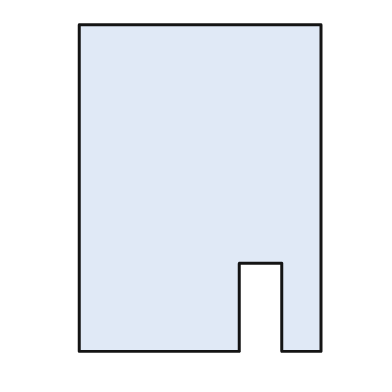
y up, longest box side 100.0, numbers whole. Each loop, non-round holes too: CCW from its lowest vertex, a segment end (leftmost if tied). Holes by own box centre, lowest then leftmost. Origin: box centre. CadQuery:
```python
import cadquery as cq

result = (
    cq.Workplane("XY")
    .moveTo(-37.0, -50.0)
    .lineTo(12.0, -50.0)
    .lineTo(12.0, -23.0)
    .lineTo(25.0, -23.0)
    .lineTo(25.0, -50.0)
    .lineTo(37.0, -50.0)
    .lineTo(37.0, 50.0)
    .lineTo(-37.0, 50.0)
    .close()
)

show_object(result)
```